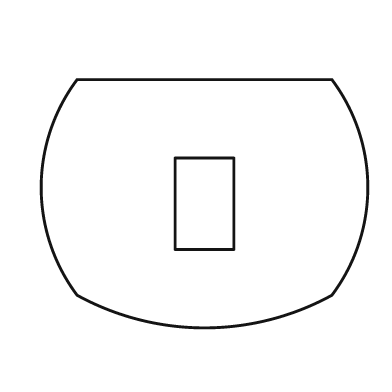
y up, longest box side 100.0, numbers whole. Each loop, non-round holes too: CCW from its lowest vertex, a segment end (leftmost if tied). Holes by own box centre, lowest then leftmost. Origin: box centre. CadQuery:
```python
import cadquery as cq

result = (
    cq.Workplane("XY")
    .moveTo(-39.0, -28.0)
    .threePointArc((0.0, -38.0), (39.0, -28.0))
    .threePointArc((50.0, 5.0), (39.0, 38.0))
    .lineTo(-39.0, 38.0)
    .threePointArc((-50.0, 5.0), (-39.0, -28.0))
    .close()
    .moveTo(-9.0, -14.0)
    .lineTo(9.0, -14.0)
    .lineTo(9.0, 14.0)
    .lineTo(-9.0, 14.0)
    .close()
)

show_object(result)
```